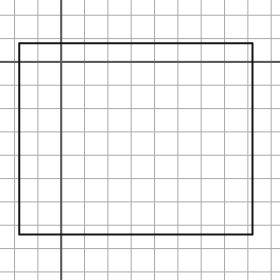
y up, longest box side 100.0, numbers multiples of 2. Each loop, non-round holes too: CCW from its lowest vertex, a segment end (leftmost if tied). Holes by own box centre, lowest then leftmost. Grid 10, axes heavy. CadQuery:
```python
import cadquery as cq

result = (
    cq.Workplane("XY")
    .moveTo(-18.0, -74.0)
    .lineTo(82.0, -74.0)
    .lineTo(82.0, 8.0)
    .lineTo(-18.0, 8.0)
    .close()
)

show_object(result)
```